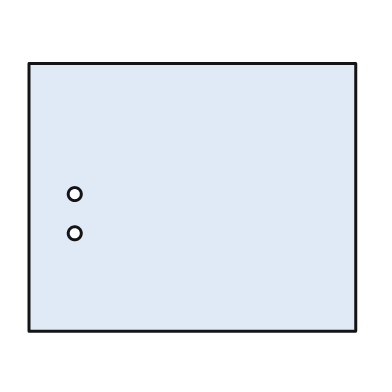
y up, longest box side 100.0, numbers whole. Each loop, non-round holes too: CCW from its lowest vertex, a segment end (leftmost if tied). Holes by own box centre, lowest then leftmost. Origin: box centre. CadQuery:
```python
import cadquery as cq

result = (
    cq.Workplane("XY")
    .moveTo(-50.0, -41.0)
    .lineTo(50.0, -41.0)
    .lineTo(50.0, 41.0)
    .lineTo(-50.0, 41.0)
    .close()
    .moveTo(-36.0, -11.0)
    .circle(2.0)
    .moveTo(-36.0, 1.0)
    .circle(2.0)
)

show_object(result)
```